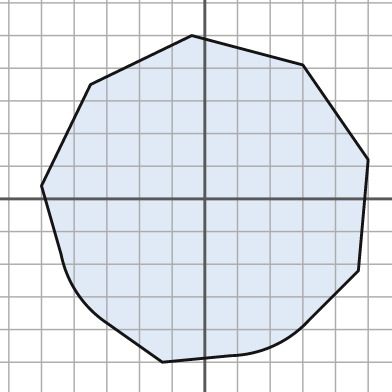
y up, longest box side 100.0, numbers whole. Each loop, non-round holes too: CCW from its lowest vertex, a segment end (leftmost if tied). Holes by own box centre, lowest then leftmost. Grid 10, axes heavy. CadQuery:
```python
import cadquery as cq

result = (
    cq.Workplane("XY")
    .moveTo(-13.0, -50.0)
    .lineTo(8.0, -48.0)
    .threePointArc((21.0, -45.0), (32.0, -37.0))
    .lineTo(47.0, -22.0)
    .lineTo(50.0, 12.0)
    .lineTo(30.0, 41.0)
    .lineTo(-4.0, 50.0)
    .lineTo(-35.0, 35.0)
    .lineTo(-50.0, 4.0)
    .lineTo(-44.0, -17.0)
    .threePointArc((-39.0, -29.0), (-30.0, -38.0))
    .close()
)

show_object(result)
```